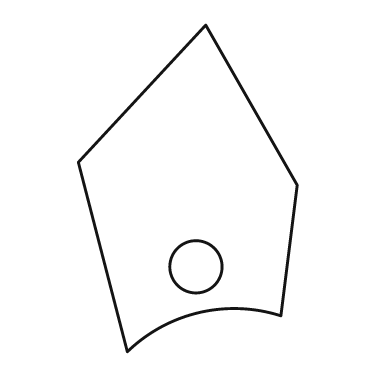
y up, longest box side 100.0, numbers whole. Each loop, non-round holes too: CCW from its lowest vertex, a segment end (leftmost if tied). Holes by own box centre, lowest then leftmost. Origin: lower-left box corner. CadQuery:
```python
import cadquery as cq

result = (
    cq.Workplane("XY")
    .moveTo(15.0, 0.0)
    .threePointArc((37.0, 12.0), (62.0, 11.0))
    .lineTo(67.0, 51.0)
    .lineTo(39.0, 100.0)
    .lineTo(0.0, 58.0)
    .close()
    .moveTo(36.0, 26.0)
    .circle(8.0)
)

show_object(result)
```